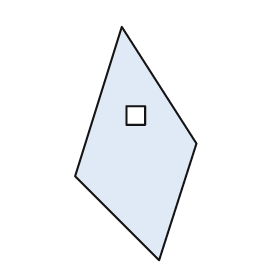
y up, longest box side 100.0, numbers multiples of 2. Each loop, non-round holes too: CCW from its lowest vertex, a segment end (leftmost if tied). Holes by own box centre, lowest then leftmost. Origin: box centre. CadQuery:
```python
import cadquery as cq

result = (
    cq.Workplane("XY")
    .moveTo(10.0, -50.0)
    .lineTo(26.0, 0.0)
    .lineTo(-6.0, 50.0)
    .lineTo(-26.0, -14.0)
    .close()
    .moveTo(-4.0, 8.0)
    .lineTo(4.0, 8.0)
    .lineTo(4.0, 16.0)
    .lineTo(-4.0, 16.0)
    .close()
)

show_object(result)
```